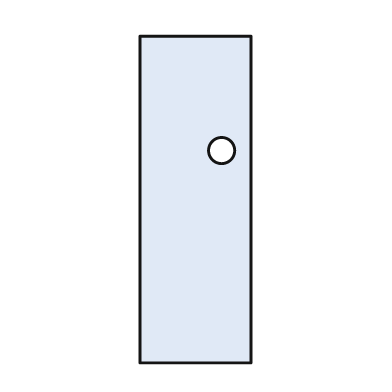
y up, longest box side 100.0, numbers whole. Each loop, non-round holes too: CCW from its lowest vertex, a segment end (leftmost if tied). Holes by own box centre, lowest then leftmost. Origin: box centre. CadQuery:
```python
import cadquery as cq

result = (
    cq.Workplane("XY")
    .moveTo(-17.0, -50.0)
    .lineTo(17.0, -50.0)
    .lineTo(17.0, 50.0)
    .lineTo(-17.0, 50.0)
    .close()
    .moveTo(8.0, 15.0)
    .circle(4.0)
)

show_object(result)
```